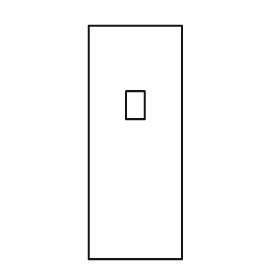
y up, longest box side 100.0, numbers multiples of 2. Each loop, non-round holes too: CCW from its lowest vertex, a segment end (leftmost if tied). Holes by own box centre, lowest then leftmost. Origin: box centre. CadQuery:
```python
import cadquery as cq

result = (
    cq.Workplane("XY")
    .moveTo(-20.0, -50.0)
    .lineTo(20.0, -50.0)
    .lineTo(20.0, 50.0)
    .lineTo(-20.0, 50.0)
    .close()
    .moveTo(-4.0, 10.0)
    .lineTo(4.0, 10.0)
    .lineTo(4.0, 22.0)
    .lineTo(-4.0, 22.0)
    .close()
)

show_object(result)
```